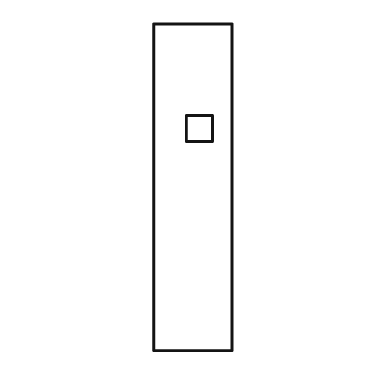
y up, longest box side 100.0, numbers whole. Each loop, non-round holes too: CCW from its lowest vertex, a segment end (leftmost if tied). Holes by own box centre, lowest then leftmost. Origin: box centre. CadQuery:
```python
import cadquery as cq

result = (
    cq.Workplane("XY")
    .moveTo(-12.0, -50.0)
    .lineTo(12.0, -50.0)
    .lineTo(12.0, 50.0)
    .lineTo(-12.0, 50.0)
    .close()
    .moveTo(-2.0, 14.0)
    .lineTo(6.0, 14.0)
    .lineTo(6.0, 22.0)
    .lineTo(-2.0, 22.0)
    .close()
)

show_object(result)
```